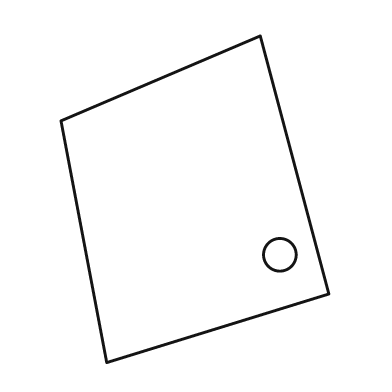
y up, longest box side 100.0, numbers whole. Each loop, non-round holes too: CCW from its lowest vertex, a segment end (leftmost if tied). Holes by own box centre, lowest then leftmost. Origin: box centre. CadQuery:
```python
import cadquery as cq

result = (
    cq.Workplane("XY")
    .moveTo(-27.0, -50.0)
    .lineTo(41.0, -29.0)
    .lineTo(20.0, 50.0)
    .lineTo(-41.0, 24.0)
    .close()
    .moveTo(26.0, -17.0)
    .circle(5.0)
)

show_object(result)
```